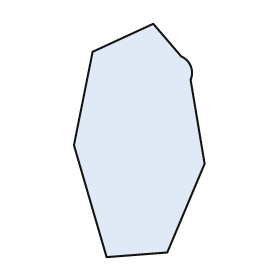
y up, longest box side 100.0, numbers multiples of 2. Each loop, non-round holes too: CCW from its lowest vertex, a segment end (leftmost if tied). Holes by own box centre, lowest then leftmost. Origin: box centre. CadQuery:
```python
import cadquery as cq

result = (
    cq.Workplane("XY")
    .moveTo(-14.0, -50.0)
    .lineTo(12.0, -48.0)
    .lineTo(28.0, -10.0)
    .lineTo(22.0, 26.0)
    .threePointArc((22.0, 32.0), (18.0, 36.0))
    .lineTo(6.0, 50.0)
    .lineTo(-20.0, 38.0)
    .lineTo(-28.0, -2.0)
    .close()
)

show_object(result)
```